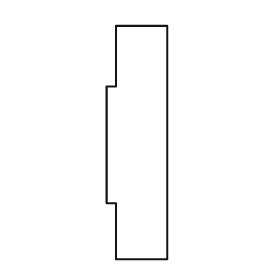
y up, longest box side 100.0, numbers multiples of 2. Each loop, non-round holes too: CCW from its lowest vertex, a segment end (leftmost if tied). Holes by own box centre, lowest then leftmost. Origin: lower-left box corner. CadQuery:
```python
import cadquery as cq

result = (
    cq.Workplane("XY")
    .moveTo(4.0, 0.0)
    .lineTo(26.0, 0.0)
    .lineTo(26.0, 100.0)
    .lineTo(4.0, 100.0)
    .lineTo(4.0, 74.0)
    .lineTo(0.0, 74.0)
    .lineTo(0.0, 24.0)
    .lineTo(4.0, 24.0)
    .close()
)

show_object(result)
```